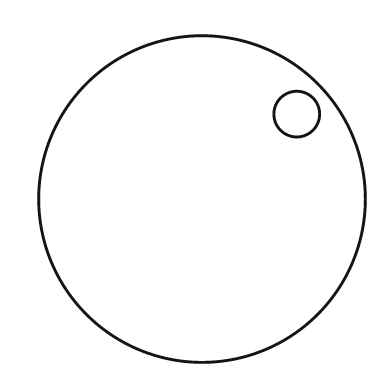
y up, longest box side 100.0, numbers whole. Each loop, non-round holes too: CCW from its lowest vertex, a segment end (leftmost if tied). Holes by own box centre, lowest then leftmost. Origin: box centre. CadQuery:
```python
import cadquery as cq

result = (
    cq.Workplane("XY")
    .moveTo(0.0, 0.0)
    .circle(50.0)
    .moveTo(29.0, 26.0)
    .circle(7.0)
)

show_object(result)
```